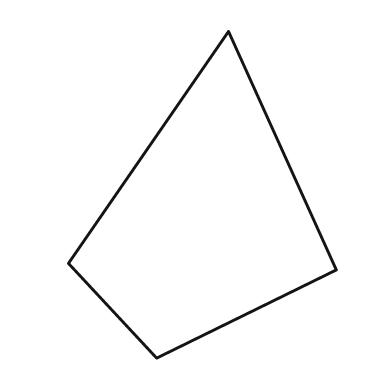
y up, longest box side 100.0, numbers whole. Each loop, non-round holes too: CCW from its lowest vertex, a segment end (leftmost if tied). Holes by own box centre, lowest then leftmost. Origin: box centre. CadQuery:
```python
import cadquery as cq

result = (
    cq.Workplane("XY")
    .moveTo(-14.0, -50.0)
    .lineTo(41.0, -23.0)
    .lineTo(8.0, 50.0)
    .lineTo(-41.0, -21.0)
    .close()
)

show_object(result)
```